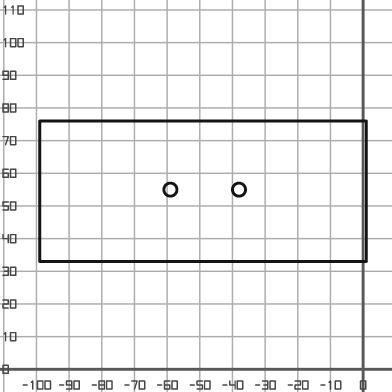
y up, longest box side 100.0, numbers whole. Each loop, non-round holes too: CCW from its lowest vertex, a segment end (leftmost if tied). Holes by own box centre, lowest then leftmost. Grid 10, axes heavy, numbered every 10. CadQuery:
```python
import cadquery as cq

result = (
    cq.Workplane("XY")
    .moveTo(-99.0, 33.0)
    .lineTo(1.0, 33.0)
    .lineTo(1.0, 76.0)
    .lineTo(-99.0, 76.0)
    .close()
    .moveTo(-59.0, 55.0)
    .circle(2.0)
    .moveTo(-38.0, 55.0)
    .circle(2.0)
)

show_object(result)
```